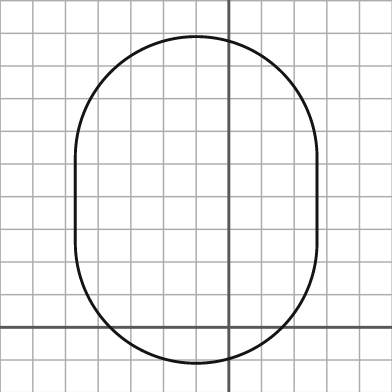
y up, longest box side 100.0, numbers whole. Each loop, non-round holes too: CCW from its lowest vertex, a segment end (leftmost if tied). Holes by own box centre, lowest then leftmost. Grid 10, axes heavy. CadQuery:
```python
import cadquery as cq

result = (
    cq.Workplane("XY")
    .moveTo(-47.0, 26.0)
    .threePointArc((-10.0, -11.0), (27.0, 26.0))
    .lineTo(27.0, 52.0)
    .threePointArc((-10.0, 89.0), (-47.0, 52.0))
    .close()
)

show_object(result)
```